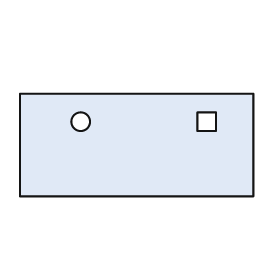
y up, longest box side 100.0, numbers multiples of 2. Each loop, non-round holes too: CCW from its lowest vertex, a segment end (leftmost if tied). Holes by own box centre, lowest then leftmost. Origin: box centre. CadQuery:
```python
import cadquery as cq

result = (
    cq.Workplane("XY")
    .moveTo(-50.0, -22.0)
    .lineTo(50.0, -22.0)
    .lineTo(50.0, 22.0)
    .lineTo(-50.0, 22.0)
    .close()
    .moveTo(-24.0, 10.0)
    .circle(4.0)
    .moveTo(26.0, 6.0)
    .lineTo(34.0, 6.0)
    .lineTo(34.0, 14.0)
    .lineTo(26.0, 14.0)
    .close()
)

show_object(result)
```